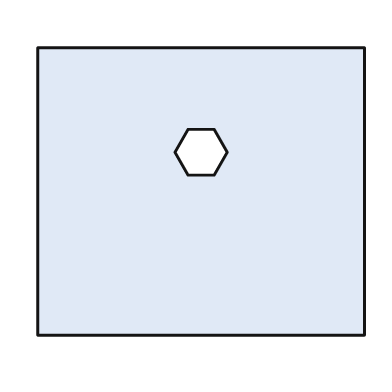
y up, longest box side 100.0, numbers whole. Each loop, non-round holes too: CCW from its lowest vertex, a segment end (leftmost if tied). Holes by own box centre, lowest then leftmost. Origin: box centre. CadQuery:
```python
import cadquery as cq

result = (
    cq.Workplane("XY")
    .moveTo(-50.0, -44.0)
    .lineTo(50.0, -44.0)
    .lineTo(50.0, 44.0)
    .lineTo(-50.0, 44.0)
    .close()
    .moveTo(-4.0, 5.0)
    .lineTo(4.0, 5.0)
    .lineTo(8.0, 12.0)
    .lineTo(4.0, 19.0)
    .lineTo(-4.0, 19.0)
    .lineTo(-8.0, 12.0)
    .close()
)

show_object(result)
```